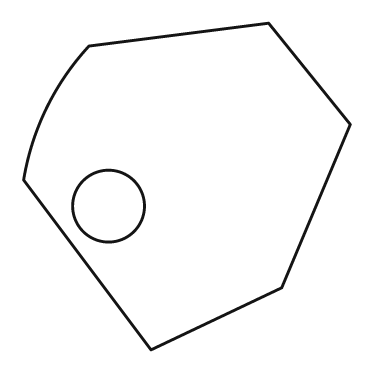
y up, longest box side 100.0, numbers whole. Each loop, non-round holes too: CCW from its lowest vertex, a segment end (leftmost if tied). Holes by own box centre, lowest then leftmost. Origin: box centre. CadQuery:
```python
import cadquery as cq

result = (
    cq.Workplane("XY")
    .moveTo(-11.0, -50.0)
    .lineTo(29.0, -31.0)
    .lineTo(50.0, 19.0)
    .lineTo(25.0, 50.0)
    .lineTo(-30.0, 43.0)
    .threePointArc((-43.0, 24.0), (-50.0, 2.0))
    .close()
    .moveTo(-24.0, -6.0)
    .circle(11.0)
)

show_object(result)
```